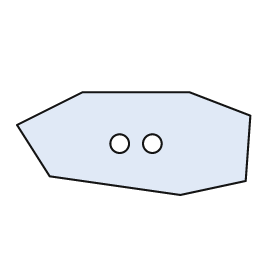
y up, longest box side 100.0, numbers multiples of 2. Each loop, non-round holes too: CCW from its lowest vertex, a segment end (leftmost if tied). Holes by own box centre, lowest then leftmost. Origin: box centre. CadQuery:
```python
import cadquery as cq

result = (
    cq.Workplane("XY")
    .moveTo(20.0, -22.0)
    .lineTo(48.0, -16.0)
    .lineTo(50.0, 12.0)
    .lineTo(24.0, 22.0)
    .lineTo(-22.0, 22.0)
    .lineTo(-50.0, 8.0)
    .lineTo(-36.0, -14.0)
    .close()
    .moveTo(-6.0, 0.0)
    .circle(4.0)
    .moveTo(8.0, 0.0)
    .circle(4.0)
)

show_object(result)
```